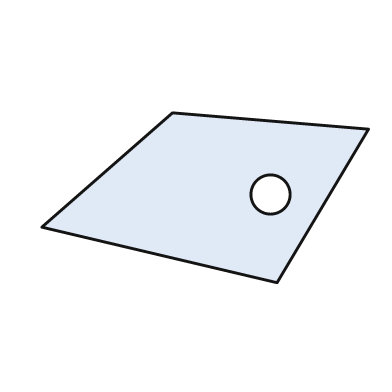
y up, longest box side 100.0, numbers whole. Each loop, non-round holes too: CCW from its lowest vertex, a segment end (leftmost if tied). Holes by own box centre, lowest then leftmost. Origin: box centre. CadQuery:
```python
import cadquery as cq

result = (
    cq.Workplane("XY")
    .moveTo(22.0, -26.0)
    .lineTo(50.0, 21.0)
    .lineTo(-10.0, 26.0)
    .lineTo(-50.0, -9.0)
    .close()
    .moveTo(20.0, 1.0)
    .circle(6.0)
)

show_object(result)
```